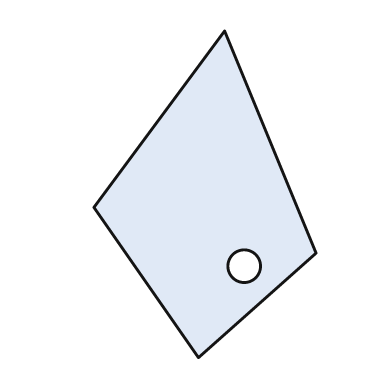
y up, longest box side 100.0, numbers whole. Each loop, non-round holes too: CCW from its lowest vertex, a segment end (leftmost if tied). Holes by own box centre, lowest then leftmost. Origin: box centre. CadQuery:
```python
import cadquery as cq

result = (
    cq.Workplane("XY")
    .moveTo(-2.0, -50.0)
    .lineTo(34.0, -18.0)
    .lineTo(6.0, 50.0)
    .lineTo(-34.0, -4.0)
    .close()
    .moveTo(12.0, -22.0)
    .circle(5.0)
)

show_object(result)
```